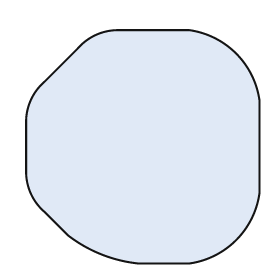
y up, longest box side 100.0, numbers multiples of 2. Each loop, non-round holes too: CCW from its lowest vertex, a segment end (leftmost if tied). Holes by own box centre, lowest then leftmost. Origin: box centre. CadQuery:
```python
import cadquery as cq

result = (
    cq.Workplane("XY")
    .moveTo(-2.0, -50.0)
    .lineTo(20.0, -50.0)
    .threePointArc((40.0, -40.0), (50.0, -20.0))
    .lineTo(50.0, 20.0)
    .threePointArc((40.0, 40.0), (20.0, 50.0))
    .lineTo(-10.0, 50.0)
    .threePointArc((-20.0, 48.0), (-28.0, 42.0))
    .lineTo(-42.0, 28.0)
    .threePointArc((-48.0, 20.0), (-50.0, 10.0))
    .lineTo(-50.0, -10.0)
    .threePointArc((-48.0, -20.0), (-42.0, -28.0))
    .lineTo(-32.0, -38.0)
    .threePointArc((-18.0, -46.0), (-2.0, -50.0))
    .close()
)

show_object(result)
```